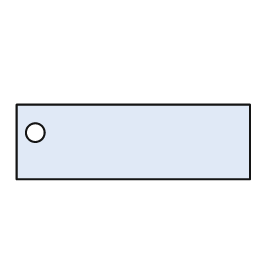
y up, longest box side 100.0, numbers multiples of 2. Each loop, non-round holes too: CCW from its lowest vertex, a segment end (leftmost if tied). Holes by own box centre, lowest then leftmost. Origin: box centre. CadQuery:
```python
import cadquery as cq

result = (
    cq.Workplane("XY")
    .moveTo(-50.0, -16.0)
    .lineTo(50.0, -16.0)
    .lineTo(50.0, 16.0)
    .lineTo(-50.0, 16.0)
    .close()
    .moveTo(-42.0, 4.0)
    .circle(4.0)
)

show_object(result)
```